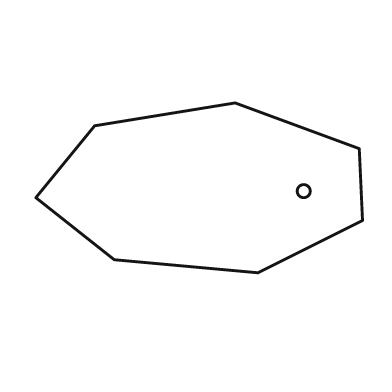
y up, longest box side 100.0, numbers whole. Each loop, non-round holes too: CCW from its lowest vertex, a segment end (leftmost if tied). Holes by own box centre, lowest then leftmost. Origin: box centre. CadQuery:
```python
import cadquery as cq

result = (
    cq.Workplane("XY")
    .moveTo(18.0, -26.0)
    .lineTo(50.0, -10.0)
    .lineTo(49.0, 12.0)
    .lineTo(11.0, 26.0)
    .lineTo(-32.0, 19.0)
    .lineTo(-50.0, -3.0)
    .lineTo(-26.0, -22.0)
    .close()
    .moveTo(32.0, -1.0)
    .circle(2.0)
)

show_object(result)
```